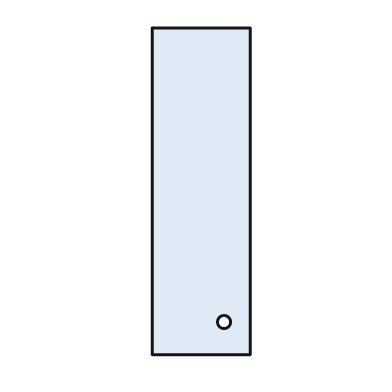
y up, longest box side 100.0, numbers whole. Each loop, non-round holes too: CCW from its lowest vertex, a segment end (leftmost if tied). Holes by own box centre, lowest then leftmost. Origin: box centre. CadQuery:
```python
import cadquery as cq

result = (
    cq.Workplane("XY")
    .moveTo(-15.0, -50.0)
    .lineTo(15.0, -50.0)
    .lineTo(15.0, 50.0)
    .lineTo(-15.0, 50.0)
    .close()
    .moveTo(7.0, -40.0)
    .circle(2.0)
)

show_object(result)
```